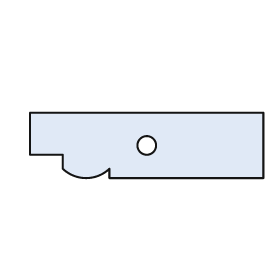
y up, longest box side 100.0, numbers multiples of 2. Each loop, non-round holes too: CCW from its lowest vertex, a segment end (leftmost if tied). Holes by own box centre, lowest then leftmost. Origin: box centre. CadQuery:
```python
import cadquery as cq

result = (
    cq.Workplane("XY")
    .moveTo(-16.0, -14.0)
    .lineTo(50.0, -14.0)
    .lineTo(50.0, 14.0)
    .lineTo(-50.0, 14.0)
    .lineTo(-50.0, -4.0)
    .lineTo(-36.0, -4.0)
    .lineTo(-36.0, -10.0)
    .threePointArc((-26.0, -14.0), (-16.0, -10.0))
    .close()
    .moveTo(0.0, 0.0)
    .circle(4.0)
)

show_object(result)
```